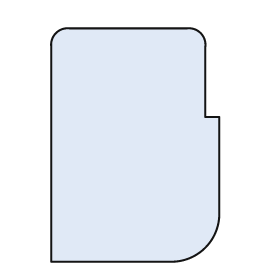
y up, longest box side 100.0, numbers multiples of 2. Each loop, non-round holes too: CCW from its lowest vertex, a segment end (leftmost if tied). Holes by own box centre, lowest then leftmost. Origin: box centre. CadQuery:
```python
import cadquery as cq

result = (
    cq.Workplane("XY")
    .moveTo(-36.0, -50.0)
    .lineTo(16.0, -50.0)
    .threePointArc((30.0, -44.0), (36.0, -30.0))
    .lineTo(36.0, 12.0)
    .lineTo(30.0, 12.0)
    .lineTo(30.0, 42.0)
    .threePointArc((28.0, 48.0), (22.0, 50.0))
    .lineTo(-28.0, 50.0)
    .threePointArc((-34.0, 48.0), (-36.0, 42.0))
    .close()
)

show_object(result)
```